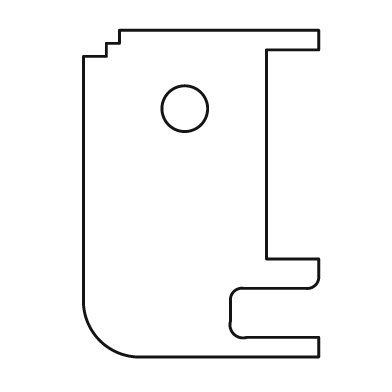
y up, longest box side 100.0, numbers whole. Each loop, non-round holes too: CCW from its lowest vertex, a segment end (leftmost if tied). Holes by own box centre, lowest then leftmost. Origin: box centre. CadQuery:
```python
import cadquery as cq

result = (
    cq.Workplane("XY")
    .moveTo(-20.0, -50.0)
    .lineTo(36.0, -50.0)
    .lineTo(36.0, -44.0)
    .lineTo(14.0, -44.0)
    .threePointArc((10.0, -43.0), (9.0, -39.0))
    .lineTo(9.0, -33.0)
    .threePointArc((10.0, -30.0), (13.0, -29.0))
    .lineTo(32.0, -29.0)
    .threePointArc((35.0, -28.0), (36.0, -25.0))
    .lineTo(36.0, -20.0)
    .lineTo(20.0, -20.0)
    .lineTo(20.0, 44.0)
    .lineTo(36.0, 44.0)
    .lineTo(36.0, 50.0)
    .lineTo(-25.0, 50.0)
    .lineTo(-25.0, 46.0)
    .lineTo(-29.0, 46.0)
    .lineTo(-29.0, 42.0)
    .lineTo(-36.0, 42.0)
    .lineTo(-36.0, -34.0)
    .threePointArc((-31.0, -45.0), (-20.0, -50.0))
    .close()
    .moveTo(-5.0, 26.0)
    .circle(7.0)
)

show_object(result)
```